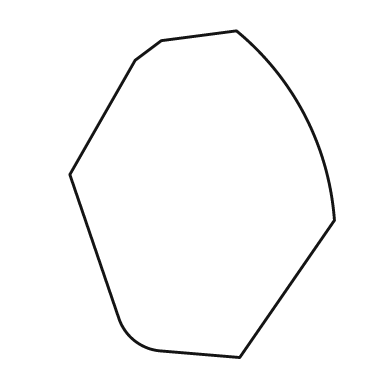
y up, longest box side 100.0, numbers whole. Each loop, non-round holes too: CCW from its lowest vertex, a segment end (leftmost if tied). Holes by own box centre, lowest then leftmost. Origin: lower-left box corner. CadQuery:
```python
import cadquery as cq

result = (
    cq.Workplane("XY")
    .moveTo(52.0, 0.0)
    .lineTo(81.0, 42.0)
    .threePointArc((72.0, 74.0), (51.0, 100.0))
    .lineTo(28.0, 97.0)
    .lineTo(20.0, 91.0)
    .lineTo(0.0, 56.0)
    .lineTo(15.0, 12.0)
    .threePointArc((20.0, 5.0), (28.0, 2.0))
    .close()
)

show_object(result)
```